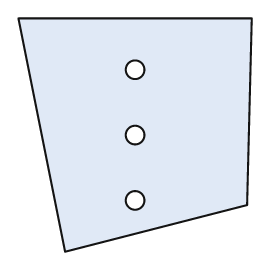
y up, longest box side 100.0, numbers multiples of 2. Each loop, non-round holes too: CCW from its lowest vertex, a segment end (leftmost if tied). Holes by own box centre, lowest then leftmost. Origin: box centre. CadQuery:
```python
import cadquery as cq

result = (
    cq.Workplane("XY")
    .moveTo(-30.0, -50.0)
    .lineTo(48.0, -30.0)
    .lineTo(50.0, 50.0)
    .lineTo(-50.0, 50.0)
    .close()
    .moveTo(0.0, -28.0)
    .circle(4.0)
    .moveTo(0.0, 0.0)
    .circle(4.0)
    .moveTo(0.0, 28.0)
    .circle(4.0)
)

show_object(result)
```